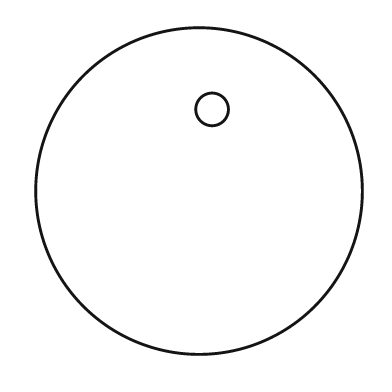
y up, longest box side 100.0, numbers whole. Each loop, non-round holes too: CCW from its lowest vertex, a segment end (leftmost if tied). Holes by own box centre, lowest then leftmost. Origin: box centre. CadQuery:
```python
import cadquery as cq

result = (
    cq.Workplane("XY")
    .moveTo(0.0, 0.0)
    .circle(50.0)
    .moveTo(4.0, 25.0)
    .circle(5.0)
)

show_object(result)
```